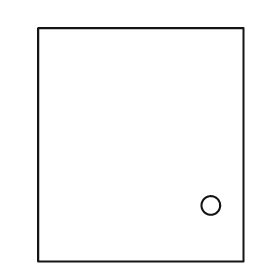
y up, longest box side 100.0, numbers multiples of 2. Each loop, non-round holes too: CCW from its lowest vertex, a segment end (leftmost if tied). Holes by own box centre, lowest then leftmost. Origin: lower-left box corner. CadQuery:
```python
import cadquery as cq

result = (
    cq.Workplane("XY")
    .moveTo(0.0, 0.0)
    .lineTo(88.0, 0.0)
    .lineTo(88.0, 100.0)
    .lineTo(0.0, 100.0)
    .close()
    .moveTo(74.0, 24.0)
    .circle(4.0)
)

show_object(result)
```